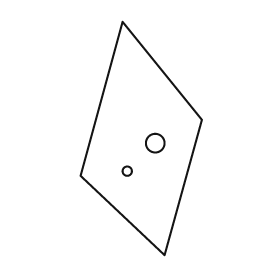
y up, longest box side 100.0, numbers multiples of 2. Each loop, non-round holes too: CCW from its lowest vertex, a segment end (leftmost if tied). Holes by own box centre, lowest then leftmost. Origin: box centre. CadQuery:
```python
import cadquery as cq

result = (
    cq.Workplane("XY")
    .moveTo(10.0, -50.0)
    .lineTo(26.0, 8.0)
    .lineTo(-8.0, 50.0)
    .lineTo(-26.0, -16.0)
    .close()
    .moveTo(-6.0, -14.0)
    .circle(2.0)
    .moveTo(6.0, -2.0)
    .circle(4.0)
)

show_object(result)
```